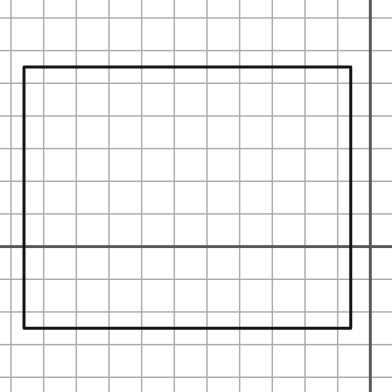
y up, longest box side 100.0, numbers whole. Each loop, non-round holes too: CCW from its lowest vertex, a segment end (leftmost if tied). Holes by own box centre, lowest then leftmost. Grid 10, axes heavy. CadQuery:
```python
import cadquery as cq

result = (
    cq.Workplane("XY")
    .moveTo(-106.0, -25.0)
    .lineTo(-6.0, -25.0)
    .lineTo(-6.0, 55.0)
    .lineTo(-106.0, 55.0)
    .close()
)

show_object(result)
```